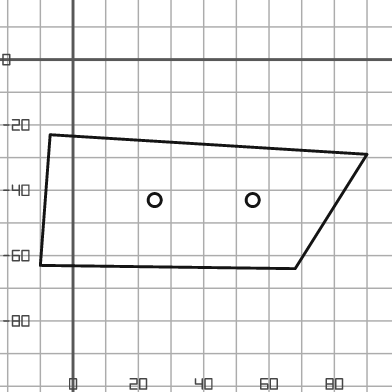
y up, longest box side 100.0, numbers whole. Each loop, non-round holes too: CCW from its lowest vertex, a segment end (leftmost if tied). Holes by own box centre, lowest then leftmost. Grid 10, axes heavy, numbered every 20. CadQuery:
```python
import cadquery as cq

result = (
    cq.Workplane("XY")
    .moveTo(68.0, -64.0)
    .lineTo(90.0, -29.0)
    .lineTo(-7.0, -23.0)
    .lineTo(-10.0, -63.0)
    .close()
    .moveTo(25.0, -43.0)
    .circle(2.0)
    .moveTo(55.0, -43.0)
    .circle(2.0)
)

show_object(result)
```